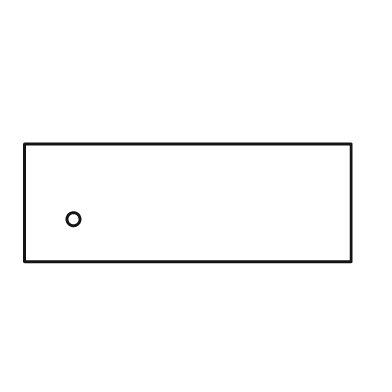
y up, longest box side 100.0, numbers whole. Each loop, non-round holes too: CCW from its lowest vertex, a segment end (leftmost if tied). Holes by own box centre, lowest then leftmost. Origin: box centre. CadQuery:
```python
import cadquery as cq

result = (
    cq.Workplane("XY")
    .moveTo(-50.0, -18.0)
    .lineTo(50.0, -18.0)
    .lineTo(50.0, 18.0)
    .lineTo(-50.0, 18.0)
    .close()
    .moveTo(-35.0, -5.0)
    .circle(2.0)
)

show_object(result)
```